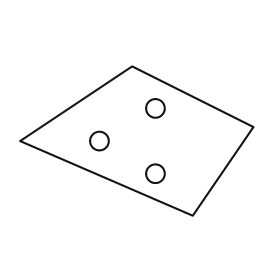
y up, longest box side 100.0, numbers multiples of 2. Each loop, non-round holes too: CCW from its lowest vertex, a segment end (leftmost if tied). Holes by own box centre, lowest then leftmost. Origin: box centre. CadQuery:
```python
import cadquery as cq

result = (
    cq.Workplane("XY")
    .moveTo(24.0, -32.0)
    .lineTo(50.0, 6.0)
    .lineTo(-2.0, 32.0)
    .lineTo(-50.0, 0.0)
    .close()
    .moveTo(8.0, -14.0)
    .circle(4.0)
    .moveTo(-16.0, 0.0)
    .circle(4.0)
    .moveTo(8.0, 14.0)
    .circle(4.0)
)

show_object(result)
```